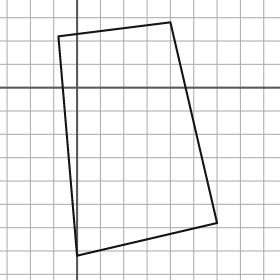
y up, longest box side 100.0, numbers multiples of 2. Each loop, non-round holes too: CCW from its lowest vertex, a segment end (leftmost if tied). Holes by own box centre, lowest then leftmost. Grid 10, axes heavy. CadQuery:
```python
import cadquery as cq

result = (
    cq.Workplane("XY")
    .moveTo(0.0, -72.0)
    .lineTo(60.0, -58.0)
    .lineTo(40.0, 28.0)
    .lineTo(-8.0, 22.0)
    .close()
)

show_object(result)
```